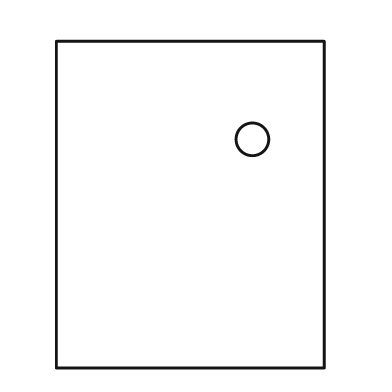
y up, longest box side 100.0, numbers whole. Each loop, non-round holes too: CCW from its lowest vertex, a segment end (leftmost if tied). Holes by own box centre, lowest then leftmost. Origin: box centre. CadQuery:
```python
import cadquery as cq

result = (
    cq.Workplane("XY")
    .moveTo(-41.0, -50.0)
    .lineTo(41.0, -50.0)
    .lineTo(41.0, 50.0)
    .lineTo(-41.0, 50.0)
    .close()
    .moveTo(19.0, 20.0)
    .circle(5.0)
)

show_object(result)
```